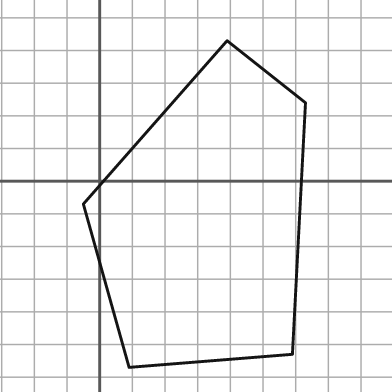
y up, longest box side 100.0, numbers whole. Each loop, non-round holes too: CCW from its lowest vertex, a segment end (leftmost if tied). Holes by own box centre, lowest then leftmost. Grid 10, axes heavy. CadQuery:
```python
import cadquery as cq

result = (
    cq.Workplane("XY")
    .moveTo(9.0, -57.0)
    .lineTo(59.0, -53.0)
    .lineTo(63.0, 24.0)
    .lineTo(39.0, 43.0)
    .lineTo(-5.0, -7.0)
    .close()
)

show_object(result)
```